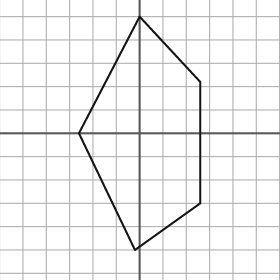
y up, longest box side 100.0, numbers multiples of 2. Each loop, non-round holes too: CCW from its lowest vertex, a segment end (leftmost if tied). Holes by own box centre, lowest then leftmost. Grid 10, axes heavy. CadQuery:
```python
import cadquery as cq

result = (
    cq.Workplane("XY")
    .moveTo(-2.0, -50.0)
    .lineTo(26.0, -30.0)
    .lineTo(26.0, 22.0)
    .lineTo(0.0, 50.0)
    .lineTo(-26.0, 0.0)
    .close()
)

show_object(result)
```